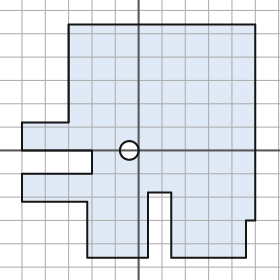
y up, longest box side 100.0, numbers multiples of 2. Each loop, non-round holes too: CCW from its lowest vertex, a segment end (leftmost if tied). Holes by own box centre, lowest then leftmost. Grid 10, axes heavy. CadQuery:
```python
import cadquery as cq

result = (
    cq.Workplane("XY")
    .moveTo(-22.0, -46.0)
    .lineTo(4.0, -46.0)
    .lineTo(4.0, -18.0)
    .lineTo(14.0, -18.0)
    .lineTo(14.0, -46.0)
    .lineTo(46.0, -46.0)
    .lineTo(46.0, -30.0)
    .lineTo(50.0, -30.0)
    .lineTo(50.0, 54.0)
    .lineTo(-30.0, 54.0)
    .lineTo(-30.0, 12.0)
    .lineTo(-50.0, 12.0)
    .lineTo(-50.0, 0.0)
    .lineTo(-20.0, 0.0)
    .lineTo(-20.0, -10.0)
    .lineTo(-50.0, -10.0)
    .lineTo(-50.0, -22.0)
    .lineTo(-22.0, -22.0)
    .close()
    .moveTo(-4.0, 0.0)
    .circle(4.0)
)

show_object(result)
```